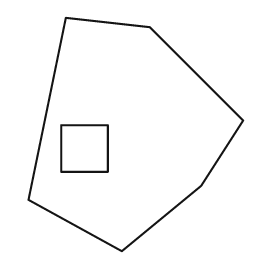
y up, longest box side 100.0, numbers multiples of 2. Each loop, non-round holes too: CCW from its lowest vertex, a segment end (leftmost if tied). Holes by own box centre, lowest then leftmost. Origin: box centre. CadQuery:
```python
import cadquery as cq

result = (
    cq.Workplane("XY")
    .moveTo(-6.0, -50.0)
    .lineTo(28.0, -22.0)
    .lineTo(46.0, 6.0)
    .lineTo(6.0, 46.0)
    .lineTo(-30.0, 50.0)
    .lineTo(-46.0, -28.0)
    .close()
    .moveTo(-32.0, -16.0)
    .lineTo(-12.0, -16.0)
    .lineTo(-12.0, 4.0)
    .lineTo(-32.0, 4.0)
    .close()
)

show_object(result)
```